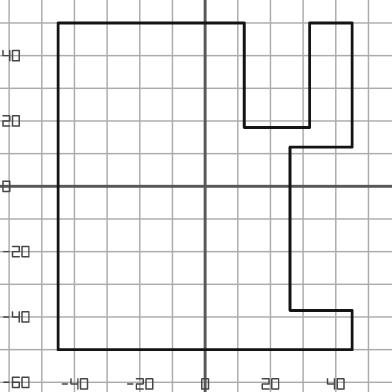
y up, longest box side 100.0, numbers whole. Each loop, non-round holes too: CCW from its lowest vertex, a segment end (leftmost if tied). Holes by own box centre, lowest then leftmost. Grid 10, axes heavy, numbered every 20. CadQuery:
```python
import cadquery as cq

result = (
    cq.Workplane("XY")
    .moveTo(-45.0, -50.0)
    .lineTo(45.0, -50.0)
    .lineTo(45.0, -38.0)
    .lineTo(26.0, -38.0)
    .lineTo(26.0, 12.0)
    .lineTo(45.0, 12.0)
    .lineTo(45.0, 50.0)
    .lineTo(32.0, 50.0)
    .lineTo(32.0, 18.0)
    .lineTo(12.0, 18.0)
    .lineTo(12.0, 50.0)
    .lineTo(-45.0, 50.0)
    .close()
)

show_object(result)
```